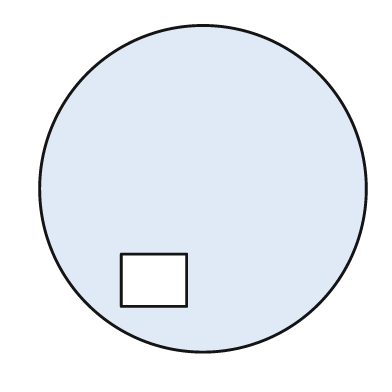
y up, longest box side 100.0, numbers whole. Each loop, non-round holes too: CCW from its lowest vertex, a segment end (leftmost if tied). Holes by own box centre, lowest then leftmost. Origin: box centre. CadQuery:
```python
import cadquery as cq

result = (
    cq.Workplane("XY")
    .moveTo(0.0, 0.0)
    .circle(50.0)
    .moveTo(-25.0, -36.0)
    .lineTo(-5.0, -36.0)
    .lineTo(-5.0, -20.0)
    .lineTo(-25.0, -20.0)
    .close()
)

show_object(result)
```